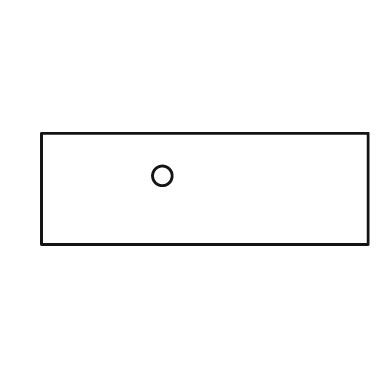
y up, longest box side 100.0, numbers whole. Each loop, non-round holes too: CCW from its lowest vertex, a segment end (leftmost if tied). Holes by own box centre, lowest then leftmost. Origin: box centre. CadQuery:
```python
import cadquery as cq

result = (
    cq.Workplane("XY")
    .moveTo(-50.0, -17.0)
    .lineTo(50.0, -17.0)
    .lineTo(50.0, 17.0)
    .lineTo(-50.0, 17.0)
    .close()
    .moveTo(-13.0, 4.0)
    .circle(3.0)
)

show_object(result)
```